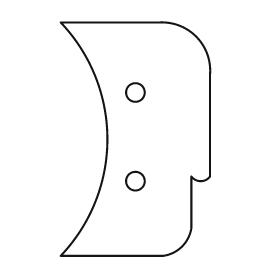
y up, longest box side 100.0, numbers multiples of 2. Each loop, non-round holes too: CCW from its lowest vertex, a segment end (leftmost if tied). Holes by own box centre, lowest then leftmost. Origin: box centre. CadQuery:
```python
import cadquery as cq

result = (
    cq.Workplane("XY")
    .moveTo(-32.0, -50.0)
    .lineTo(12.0, -50.0)
    .threePointArc((20.0, -46.0), (24.0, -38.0))
    .lineTo(24.0, -16.0)
    .threePointArc((28.0, -18.0), (32.0, -16.0))
    .lineTo(32.0, 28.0)
    .threePointArc((26.0, 44.0), (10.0, 50.0))
    .lineTo(-32.0, 50.0)
    .threePointArc((-12.0, 0.0), (-32.0, -50.0))
    .close()
    .moveTo(0.0, -18.0)
    .circle(4.0)
    .moveTo(0.0, 20.0)
    .circle(4.0)
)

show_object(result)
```